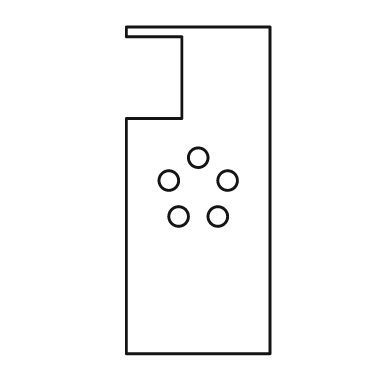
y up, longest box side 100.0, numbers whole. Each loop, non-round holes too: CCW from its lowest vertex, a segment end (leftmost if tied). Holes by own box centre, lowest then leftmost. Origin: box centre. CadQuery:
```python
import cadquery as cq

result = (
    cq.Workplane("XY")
    .moveTo(-22.0, -50.0)
    .lineTo(22.0, -50.0)
    .lineTo(22.0, 50.0)
    .lineTo(-22.0, 50.0)
    .lineTo(-22.0, 47.0)
    .lineTo(-5.0, 47.0)
    .lineTo(-5.0, 22.0)
    .lineTo(-22.0, 22.0)
    .close()
    .moveTo(-6.0, -8.0)
    .circle(3.0)
    .moveTo(6.0, -8.0)
    .circle(3.0)
    .moveTo(-9.0, 3.0)
    .circle(3.0)
    .moveTo(9.0, 3.0)
    .circle(3.0)
    .moveTo(0.0, 10.0)
    .circle(3.0)
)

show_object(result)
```